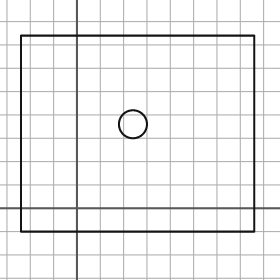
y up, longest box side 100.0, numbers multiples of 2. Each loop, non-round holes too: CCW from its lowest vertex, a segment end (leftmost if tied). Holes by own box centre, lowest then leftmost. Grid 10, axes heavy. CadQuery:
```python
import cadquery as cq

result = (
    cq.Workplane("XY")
    .moveTo(-24.0, -10.0)
    .lineTo(76.0, -10.0)
    .lineTo(76.0, 74.0)
    .lineTo(-24.0, 74.0)
    .close()
    .moveTo(24.0, 36.0)
    .circle(6.0)
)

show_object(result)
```